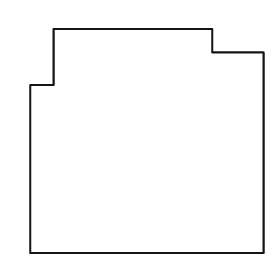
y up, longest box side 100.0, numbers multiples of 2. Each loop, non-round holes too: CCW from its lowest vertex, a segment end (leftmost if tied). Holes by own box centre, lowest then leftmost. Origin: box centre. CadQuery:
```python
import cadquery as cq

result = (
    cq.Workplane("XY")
    .moveTo(-50.0, -48.0)
    .lineTo(50.0, -48.0)
    .lineTo(50.0, 38.0)
    .lineTo(28.0, 38.0)
    .lineTo(28.0, 48.0)
    .lineTo(-40.0, 48.0)
    .lineTo(-40.0, 24.0)
    .lineTo(-50.0, 24.0)
    .close()
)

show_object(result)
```